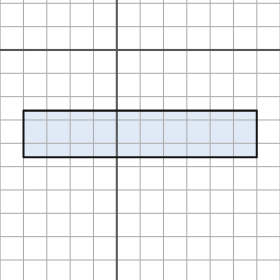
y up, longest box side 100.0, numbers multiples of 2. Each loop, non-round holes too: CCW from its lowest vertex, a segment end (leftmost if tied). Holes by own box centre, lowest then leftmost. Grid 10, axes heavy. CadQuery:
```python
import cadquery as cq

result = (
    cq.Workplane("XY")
    .moveTo(-40.0, -46.0)
    .lineTo(60.0, -46.0)
    .lineTo(60.0, -26.0)
    .lineTo(-40.0, -26.0)
    .close()
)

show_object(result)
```